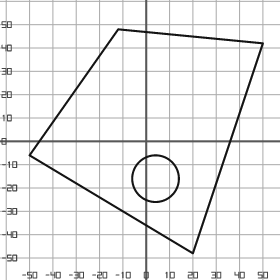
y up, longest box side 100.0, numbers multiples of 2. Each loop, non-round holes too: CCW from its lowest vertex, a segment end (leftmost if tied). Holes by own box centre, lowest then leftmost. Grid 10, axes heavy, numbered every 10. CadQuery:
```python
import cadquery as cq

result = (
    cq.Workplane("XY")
    .moveTo(20.0, -48.0)
    .lineTo(50.0, 42.0)
    .lineTo(-12.0, 48.0)
    .lineTo(-50.0, -6.0)
    .close()
    .moveTo(4.0, -16.0)
    .circle(10.0)
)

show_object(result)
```